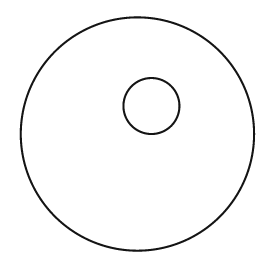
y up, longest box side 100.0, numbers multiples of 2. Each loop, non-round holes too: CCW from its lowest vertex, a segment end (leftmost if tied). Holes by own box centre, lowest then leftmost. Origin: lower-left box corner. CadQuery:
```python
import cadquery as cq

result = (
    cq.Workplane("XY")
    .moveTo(50.0, 50.0)
    .circle(50.0)
    .moveTo(56.0, 62.0)
    .circle(12.0)
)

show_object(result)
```